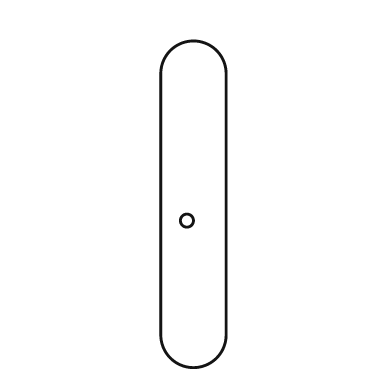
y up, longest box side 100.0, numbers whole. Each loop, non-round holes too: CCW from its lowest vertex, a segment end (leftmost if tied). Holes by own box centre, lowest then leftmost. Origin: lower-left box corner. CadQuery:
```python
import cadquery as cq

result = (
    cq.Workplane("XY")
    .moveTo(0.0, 10.0)
    .threePointArc((10.0, 0.0), (20.0, 10.0))
    .lineTo(20.0, 90.0)
    .threePointArc((10.0, 100.0), (0.0, 90.0))
    .close()
    .moveTo(8.0, 45.0)
    .circle(2.0)
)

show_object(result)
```